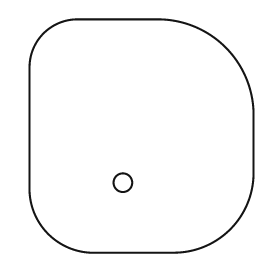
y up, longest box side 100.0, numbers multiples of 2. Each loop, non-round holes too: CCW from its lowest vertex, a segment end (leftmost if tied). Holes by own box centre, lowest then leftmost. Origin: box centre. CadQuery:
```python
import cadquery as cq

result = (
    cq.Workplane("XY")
    .moveTo(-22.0, -50.0)
    .lineTo(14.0, -50.0)
    .threePointArc((38.0, -40.0), (48.0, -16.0))
    .lineTo(48.0, 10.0)
    .threePointArc((36.0, 38.0), (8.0, 50.0))
    .lineTo(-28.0, 50.0)
    .threePointArc((-42.0, 44.0), (-48.0, 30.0))
    .lineTo(-48.0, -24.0)
    .threePointArc((-40.0, -42.0), (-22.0, -50.0))
    .close()
    .moveTo(-8.0, -20.0)
    .circle(4.0)
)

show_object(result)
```